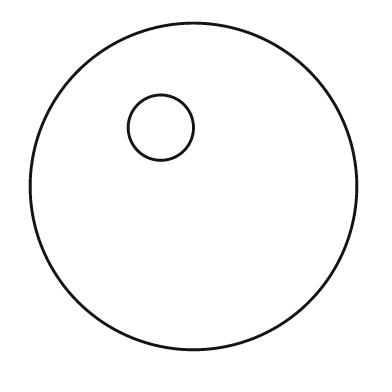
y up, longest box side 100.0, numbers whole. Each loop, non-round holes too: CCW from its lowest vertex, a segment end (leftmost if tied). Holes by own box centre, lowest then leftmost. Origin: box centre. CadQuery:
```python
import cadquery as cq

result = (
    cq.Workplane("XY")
    .moveTo(0.0, 0.0)
    .circle(50.0)
    .moveTo(-10.0, 18.0)
    .circle(10.0)
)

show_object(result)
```